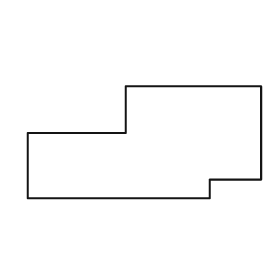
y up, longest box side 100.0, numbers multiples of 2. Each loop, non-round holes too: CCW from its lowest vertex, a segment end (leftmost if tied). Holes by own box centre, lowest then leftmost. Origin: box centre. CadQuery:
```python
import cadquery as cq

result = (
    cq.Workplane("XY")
    .moveTo(-50.0, -24.0)
    .lineTo(28.0, -24.0)
    .lineTo(28.0, -16.0)
    .lineTo(50.0, -16.0)
    .lineTo(50.0, 24.0)
    .lineTo(-8.0, 24.0)
    .lineTo(-8.0, 4.0)
    .lineTo(-50.0, 4.0)
    .close()
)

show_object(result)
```